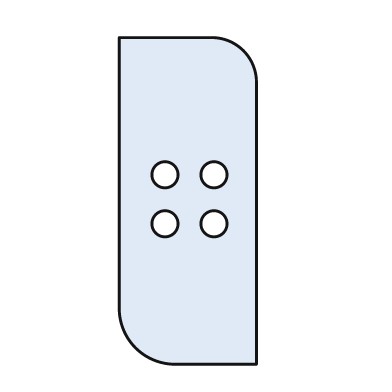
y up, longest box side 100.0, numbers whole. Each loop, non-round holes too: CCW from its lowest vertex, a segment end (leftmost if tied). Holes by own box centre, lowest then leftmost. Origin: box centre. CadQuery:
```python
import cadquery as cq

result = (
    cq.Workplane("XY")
    .moveTo(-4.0, -50.0)
    .lineTo(21.0, -50.0)
    .lineTo(21.0, 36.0)
    .threePointArc((17.0, 46.0), (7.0, 50.0))
    .lineTo(-21.0, 50.0)
    .lineTo(-21.0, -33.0)
    .threePointArc((-16.0, -45.0), (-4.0, -50.0))
    .close()
    .moveTo(-7.0, -7.0)
    .circle(4.0)
    .moveTo(8.0, -7.0)
    .circle(4.0)
    .moveTo(-7.0, 8.0)
    .circle(4.0)
    .moveTo(8.0, 8.0)
    .circle(4.0)
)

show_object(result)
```